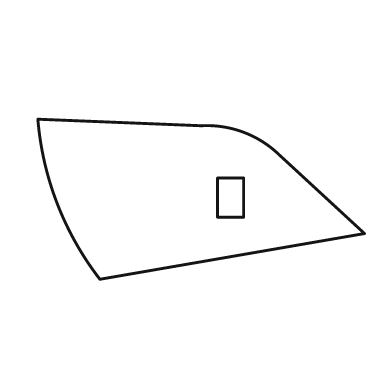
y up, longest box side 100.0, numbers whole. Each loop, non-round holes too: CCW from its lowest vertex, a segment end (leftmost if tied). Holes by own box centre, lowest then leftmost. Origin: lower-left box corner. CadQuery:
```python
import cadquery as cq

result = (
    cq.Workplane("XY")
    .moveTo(19.0, 0.0)
    .lineTo(100.0, 14.0)
    .lineTo(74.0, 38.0)
    .threePointArc((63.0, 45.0), (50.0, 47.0))
    .lineTo(0.0, 49.0)
    .threePointArc((6.0, 23.0), (19.0, 0.0))
    .close()
    .moveTo(55.0, 19.0)
    .lineTo(63.0, 19.0)
    .lineTo(63.0, 31.0)
    .lineTo(55.0, 31.0)
    .close()
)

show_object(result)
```